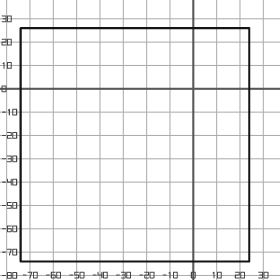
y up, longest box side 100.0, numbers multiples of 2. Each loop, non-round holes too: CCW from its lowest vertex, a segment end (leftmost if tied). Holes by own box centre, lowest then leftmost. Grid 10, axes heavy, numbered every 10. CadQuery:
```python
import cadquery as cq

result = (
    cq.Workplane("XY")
    .moveTo(-74.0, -74.0)
    .lineTo(24.0, -74.0)
    .lineTo(24.0, 26.0)
    .lineTo(-74.0, 26.0)
    .close()
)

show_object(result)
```